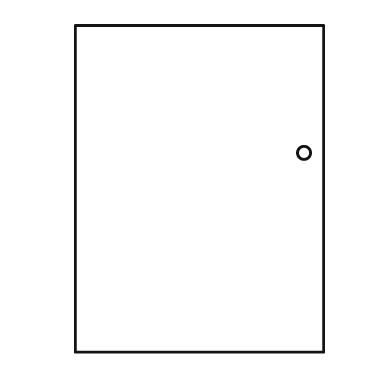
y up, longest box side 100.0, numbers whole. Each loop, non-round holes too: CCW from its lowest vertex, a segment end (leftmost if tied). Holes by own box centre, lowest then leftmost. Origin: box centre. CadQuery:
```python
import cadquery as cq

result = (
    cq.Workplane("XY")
    .moveTo(-38.0, -50.0)
    .lineTo(38.0, -50.0)
    .lineTo(38.0, 50.0)
    .lineTo(-38.0, 50.0)
    .close()
    .moveTo(32.0, 11.0)
    .circle(2.0)
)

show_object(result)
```